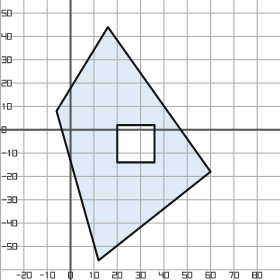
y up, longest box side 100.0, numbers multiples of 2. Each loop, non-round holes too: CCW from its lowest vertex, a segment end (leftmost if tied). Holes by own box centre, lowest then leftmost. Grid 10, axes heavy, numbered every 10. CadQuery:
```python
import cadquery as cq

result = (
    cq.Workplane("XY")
    .moveTo(12.0, -56.0)
    .lineTo(60.0, -18.0)
    .lineTo(16.0, 44.0)
    .lineTo(-6.0, 8.0)
    .close()
    .moveTo(20.0, -14.0)
    .lineTo(36.0, -14.0)
    .lineTo(36.0, 2.0)
    .lineTo(20.0, 2.0)
    .close()
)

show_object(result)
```